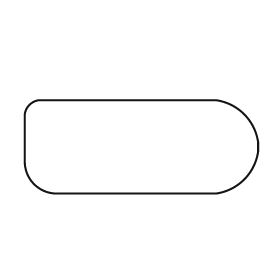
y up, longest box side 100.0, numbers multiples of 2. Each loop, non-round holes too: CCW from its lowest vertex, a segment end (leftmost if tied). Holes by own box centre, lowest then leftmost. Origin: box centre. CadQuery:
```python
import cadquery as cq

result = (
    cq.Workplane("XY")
    .moveTo(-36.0, -20.0)
    .lineTo(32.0, -20.0)
    .threePointArc((44.0, -14.0), (50.0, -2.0))
    .lineTo(50.0, 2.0)
    .threePointArc((44.0, 14.0), (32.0, 20.0))
    .lineTo(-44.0, 20.0)
    .threePointArc((-48.0, 18.0), (-50.0, 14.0))
    .lineTo(-50.0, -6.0)
    .threePointArc((-46.0, -16.0), (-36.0, -20.0))
    .close()
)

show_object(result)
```